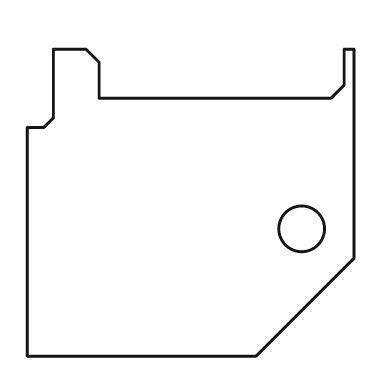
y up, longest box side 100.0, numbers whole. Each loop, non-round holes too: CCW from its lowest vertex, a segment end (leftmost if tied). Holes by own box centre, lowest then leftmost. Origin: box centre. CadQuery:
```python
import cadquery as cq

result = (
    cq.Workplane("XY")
    .moveTo(-50.0, -47.0)
    .lineTo(20.0, -47.0)
    .lineTo(50.0, -17.0)
    .lineTo(50.0, 47.0)
    .lineTo(47.0, 47.0)
    .lineTo(47.0, 36.0)
    .lineTo(43.0, 32.0)
    .lineTo(-28.0, 32.0)
    .lineTo(-28.0, 43.0)
    .lineTo(-32.0, 47.0)
    .lineTo(-42.0, 47.0)
    .lineTo(-42.0, 26.0)
    .lineTo(-45.0, 23.0)
    .lineTo(-50.0, 23.0)
    .close()
    .moveTo(34.0, -8.0)
    .circle(7.0)
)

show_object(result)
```